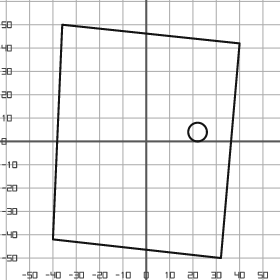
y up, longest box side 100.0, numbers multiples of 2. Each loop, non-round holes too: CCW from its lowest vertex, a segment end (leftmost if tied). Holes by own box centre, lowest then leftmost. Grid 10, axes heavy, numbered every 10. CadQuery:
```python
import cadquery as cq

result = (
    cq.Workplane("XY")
    .moveTo(32.0, -50.0)
    .lineTo(40.0, 42.0)
    .lineTo(-36.0, 50.0)
    .lineTo(-40.0, -42.0)
    .close()
    .moveTo(22.0, 4.0)
    .circle(4.0)
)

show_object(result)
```